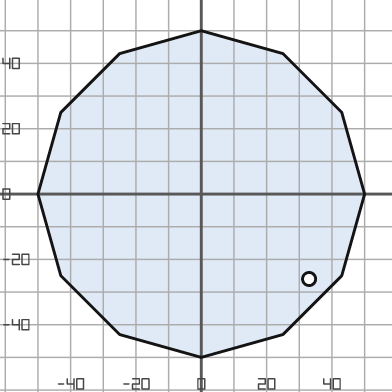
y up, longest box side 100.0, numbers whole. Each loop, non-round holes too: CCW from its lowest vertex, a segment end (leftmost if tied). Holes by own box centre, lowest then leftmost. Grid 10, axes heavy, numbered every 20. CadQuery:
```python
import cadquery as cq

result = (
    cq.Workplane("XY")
    .moveTo(0.0, -50.0)
    .lineTo(25.0, -43.0)
    .lineTo(43.0, -25.0)
    .lineTo(50.0, 0.0)
    .lineTo(43.0, 25.0)
    .lineTo(25.0, 43.0)
    .lineTo(0.0, 50.0)
    .lineTo(-25.0, 43.0)
    .lineTo(-43.0, 25.0)
    .lineTo(-50.0, 0.0)
    .lineTo(-43.0, -25.0)
    .lineTo(-25.0, -43.0)
    .close()
    .moveTo(33.0, -26.0)
    .circle(2.0)
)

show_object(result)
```